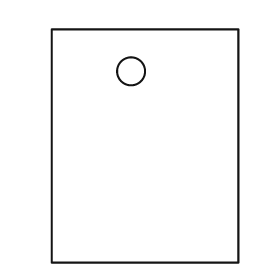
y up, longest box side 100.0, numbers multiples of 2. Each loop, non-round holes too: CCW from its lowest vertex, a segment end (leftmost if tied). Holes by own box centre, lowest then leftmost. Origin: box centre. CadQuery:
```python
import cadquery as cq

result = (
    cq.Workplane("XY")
    .moveTo(-40.0, -50.0)
    .lineTo(40.0, -50.0)
    .lineTo(40.0, 50.0)
    .lineTo(-40.0, 50.0)
    .close()
    .moveTo(-6.0, 32.0)
    .circle(6.0)
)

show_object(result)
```